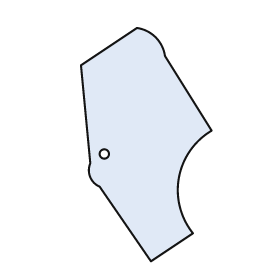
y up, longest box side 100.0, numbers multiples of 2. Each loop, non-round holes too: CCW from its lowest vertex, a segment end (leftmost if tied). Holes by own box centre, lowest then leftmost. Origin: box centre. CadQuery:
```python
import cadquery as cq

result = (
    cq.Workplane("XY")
    .moveTo(2.0, -50.0)
    .lineTo(20.0, -38.0)
    .threePointArc((14.0, -14.0), (28.0, 6.0))
    .lineTo(8.0, 38.0)
    .threePointArc((4.0, 46.0), (-4.0, 50.0))
    .lineTo(-28.0, 34.0)
    .lineTo(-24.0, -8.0)
    .threePointArc((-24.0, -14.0), (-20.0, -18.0))
    .close()
    .moveTo(-18.0, -4.0)
    .circle(2.0)
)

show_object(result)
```